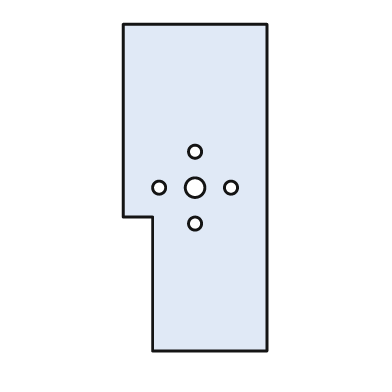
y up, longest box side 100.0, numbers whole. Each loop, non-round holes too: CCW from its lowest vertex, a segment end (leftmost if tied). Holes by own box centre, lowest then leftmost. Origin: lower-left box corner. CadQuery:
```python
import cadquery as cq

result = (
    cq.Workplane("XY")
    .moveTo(9.0, 0.0)
    .lineTo(44.0, 0.0)
    .lineTo(44.0, 100.0)
    .lineTo(0.0, 100.0)
    .lineTo(0.0, 41.0)
    .lineTo(9.0, 41.0)
    .close()
    .moveTo(22.0, 39.0)
    .circle(2.0)
    .moveTo(11.0, 50.0)
    .circle(2.0)
    .moveTo(22.0, 50.0)
    .circle(3.0)
    .moveTo(33.0, 50.0)
    .circle(2.0)
    .moveTo(22.0, 61.0)
    .circle(2.0)
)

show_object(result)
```